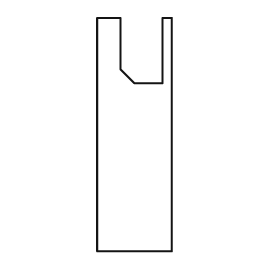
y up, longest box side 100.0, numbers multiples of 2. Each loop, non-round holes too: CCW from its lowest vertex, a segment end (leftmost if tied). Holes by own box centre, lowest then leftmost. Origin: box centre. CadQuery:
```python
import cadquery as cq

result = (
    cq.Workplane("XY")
    .moveTo(-16.0, -50.0)
    .lineTo(16.0, -50.0)
    .lineTo(16.0, 50.0)
    .lineTo(12.0, 50.0)
    .lineTo(12.0, 22.0)
    .lineTo(0.0, 22.0)
    .lineTo(-6.0, 28.0)
    .lineTo(-6.0, 50.0)
    .lineTo(-16.0, 50.0)
    .close()
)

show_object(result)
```